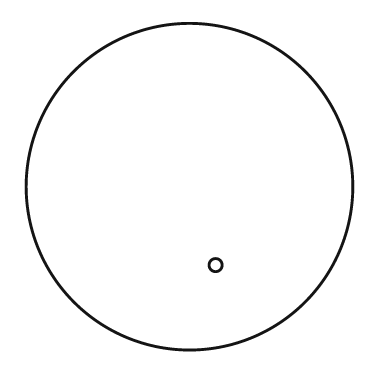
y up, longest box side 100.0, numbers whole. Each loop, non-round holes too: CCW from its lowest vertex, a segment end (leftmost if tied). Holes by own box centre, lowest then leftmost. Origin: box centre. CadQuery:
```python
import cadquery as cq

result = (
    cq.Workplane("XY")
    .moveTo(0.0, 0.0)
    .circle(50.0)
    .moveTo(8.0, -24.0)
    .circle(2.0)
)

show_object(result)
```